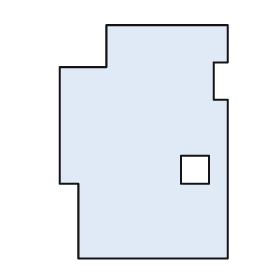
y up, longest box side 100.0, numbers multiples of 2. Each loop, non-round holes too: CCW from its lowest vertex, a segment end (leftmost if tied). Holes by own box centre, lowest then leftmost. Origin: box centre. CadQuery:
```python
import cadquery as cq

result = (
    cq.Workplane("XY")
    .moveTo(-28.0, -50.0)
    .lineTo(36.0, -50.0)
    .lineTo(36.0, 18.0)
    .lineTo(30.0, 18.0)
    .lineTo(30.0, 34.0)
    .lineTo(36.0, 34.0)
    .lineTo(36.0, 50.0)
    .lineTo(-16.0, 50.0)
    .lineTo(-16.0, 32.0)
    .lineTo(-36.0, 32.0)
    .lineTo(-36.0, -18.0)
    .lineTo(-28.0, -18.0)
    .close()
    .moveTo(16.0, -18.0)
    .lineTo(28.0, -18.0)
    .lineTo(28.0, -6.0)
    .lineTo(16.0, -6.0)
    .close()
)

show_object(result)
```